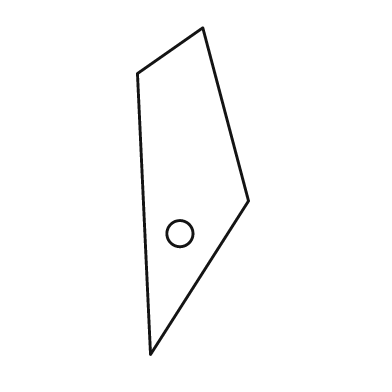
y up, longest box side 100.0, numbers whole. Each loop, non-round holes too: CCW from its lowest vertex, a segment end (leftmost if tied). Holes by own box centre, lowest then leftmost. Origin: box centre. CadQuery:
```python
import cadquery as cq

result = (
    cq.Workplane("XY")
    .moveTo(-13.0, -50.0)
    .lineTo(17.0, -3.0)
    .lineTo(3.0, 50.0)
    .lineTo(-17.0, 36.0)
    .close()
    .moveTo(-4.0, -13.0)
    .circle(4.0)
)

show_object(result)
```